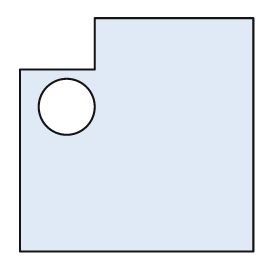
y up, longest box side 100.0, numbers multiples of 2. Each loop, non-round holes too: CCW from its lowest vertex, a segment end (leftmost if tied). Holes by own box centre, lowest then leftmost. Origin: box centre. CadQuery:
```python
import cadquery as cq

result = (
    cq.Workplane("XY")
    .moveTo(-50.0, -50.0)
    .lineTo(50.0, -50.0)
    .lineTo(50.0, 50.0)
    .lineTo(-18.0, 50.0)
    .lineTo(-18.0, 28.0)
    .lineTo(-50.0, 28.0)
    .close()
    .moveTo(-30.0, 12.0)
    .circle(12.0)
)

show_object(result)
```